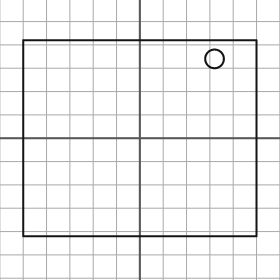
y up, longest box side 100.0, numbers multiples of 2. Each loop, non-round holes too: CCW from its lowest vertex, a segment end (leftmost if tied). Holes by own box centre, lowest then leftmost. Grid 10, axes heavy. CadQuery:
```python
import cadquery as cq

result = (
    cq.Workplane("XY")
    .moveTo(-50.0, -42.0)
    .lineTo(50.0, -42.0)
    .lineTo(50.0, 42.0)
    .lineTo(-50.0, 42.0)
    .close()
    .moveTo(32.0, 34.0)
    .circle(4.0)
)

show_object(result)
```